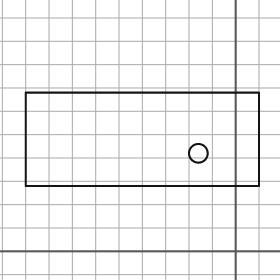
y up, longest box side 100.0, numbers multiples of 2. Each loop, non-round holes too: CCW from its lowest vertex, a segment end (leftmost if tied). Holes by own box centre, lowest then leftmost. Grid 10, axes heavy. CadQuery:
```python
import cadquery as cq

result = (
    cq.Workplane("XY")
    .moveTo(-90.0, 28.0)
    .lineTo(10.0, 28.0)
    .lineTo(10.0, 68.0)
    .lineTo(-90.0, 68.0)
    .close()
    .moveTo(-16.0, 42.0)
    .circle(4.0)
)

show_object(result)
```